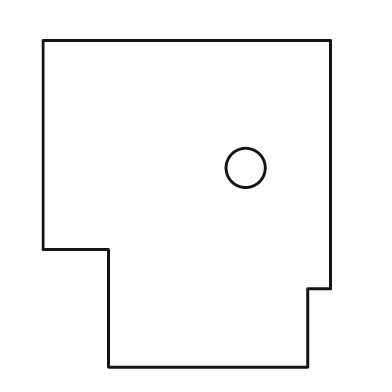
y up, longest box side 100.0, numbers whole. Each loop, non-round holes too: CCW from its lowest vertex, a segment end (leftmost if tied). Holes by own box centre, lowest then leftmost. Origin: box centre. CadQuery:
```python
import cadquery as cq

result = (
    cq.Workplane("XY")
    .moveTo(-24.0, -50.0)
    .lineTo(37.0, -50.0)
    .lineTo(37.0, -26.0)
    .lineTo(44.0, -26.0)
    .lineTo(44.0, 50.0)
    .lineTo(-44.0, 50.0)
    .lineTo(-44.0, -14.0)
    .lineTo(-24.0, -14.0)
    .close()
    .moveTo(18.0, 11.0)
    .circle(6.0)
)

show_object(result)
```